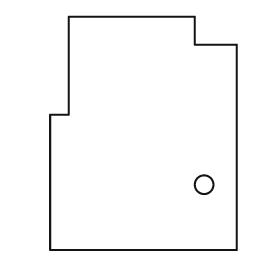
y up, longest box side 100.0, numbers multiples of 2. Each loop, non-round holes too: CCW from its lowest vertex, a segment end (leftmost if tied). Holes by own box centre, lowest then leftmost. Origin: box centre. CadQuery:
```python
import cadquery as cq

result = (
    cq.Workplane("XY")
    .moveTo(-40.0, -50.0)
    .lineTo(40.0, -50.0)
    .lineTo(40.0, 38.0)
    .lineTo(22.0, 38.0)
    .lineTo(22.0, 50.0)
    .lineTo(-32.0, 50.0)
    .lineTo(-32.0, 8.0)
    .lineTo(-40.0, 8.0)
    .close()
    .moveTo(26.0, -22.0)
    .circle(4.0)
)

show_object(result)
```